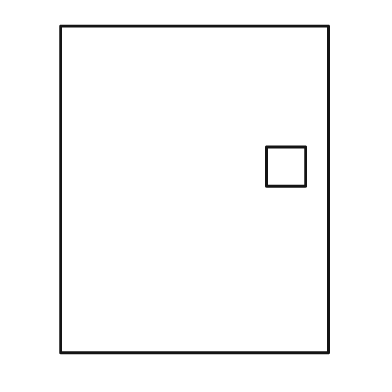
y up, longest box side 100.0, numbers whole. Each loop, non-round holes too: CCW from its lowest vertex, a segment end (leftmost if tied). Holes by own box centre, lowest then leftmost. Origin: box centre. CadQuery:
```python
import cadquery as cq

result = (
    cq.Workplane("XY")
    .moveTo(-41.0, -50.0)
    .lineTo(41.0, -50.0)
    .lineTo(41.0, 50.0)
    .lineTo(-41.0, 50.0)
    .close()
    .moveTo(22.0, 1.0)
    .lineTo(34.0, 1.0)
    .lineTo(34.0, 13.0)
    .lineTo(22.0, 13.0)
    .close()
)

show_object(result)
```